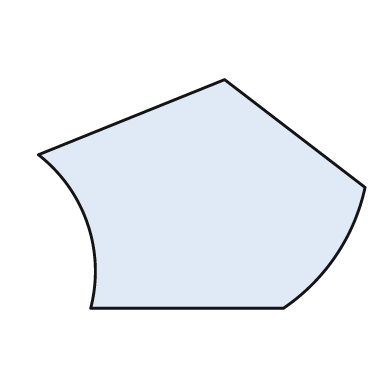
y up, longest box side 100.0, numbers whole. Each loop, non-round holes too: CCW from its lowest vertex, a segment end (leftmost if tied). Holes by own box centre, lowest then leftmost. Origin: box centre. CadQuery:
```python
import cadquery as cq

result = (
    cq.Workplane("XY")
    .moveTo(-34.0, -35.0)
    .lineTo(25.0, -35.0)
    .threePointArc((41.0, -19.0), (50.0, 2.0))
    .lineTo(7.0, 35.0)
    .lineTo(-50.0, 12.0)
    .threePointArc((-35.0, -9.0), (-34.0, -35.0))
    .close()
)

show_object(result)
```